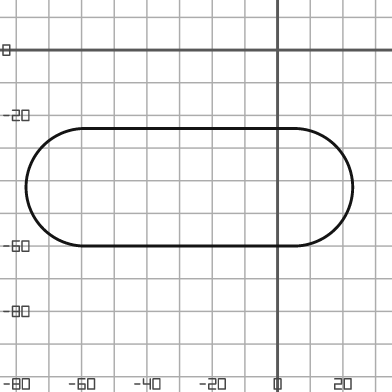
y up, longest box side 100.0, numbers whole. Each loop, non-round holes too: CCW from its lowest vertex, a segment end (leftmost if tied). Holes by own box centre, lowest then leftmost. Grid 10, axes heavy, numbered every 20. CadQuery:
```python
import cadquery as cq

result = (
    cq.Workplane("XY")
    .moveTo(-59.0, -60.0)
    .lineTo(5.0, -60.0)
    .threePointArc((23.0, -42.0), (5.0, -24.0))
    .lineTo(-59.0, -24.0)
    .threePointArc((-77.0, -42.0), (-59.0, -60.0))
    .close()
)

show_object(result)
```